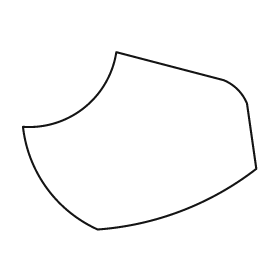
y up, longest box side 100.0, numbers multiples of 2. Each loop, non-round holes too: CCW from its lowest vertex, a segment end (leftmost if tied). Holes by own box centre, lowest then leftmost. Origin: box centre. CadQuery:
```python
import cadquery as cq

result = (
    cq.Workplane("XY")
    .moveTo(-18.0, -38.0)
    .threePointArc((18.0, -30.0), (50.0, -12.0))
    .lineTo(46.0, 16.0)
    .threePointArc((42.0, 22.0), (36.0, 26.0))
    .lineTo(-10.0, 38.0)
    .threePointArc((-24.0, 14.0), (-50.0, 6.0))
    .threePointArc((-40.0, -20.0), (-18.0, -38.0))
    .close()
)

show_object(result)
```